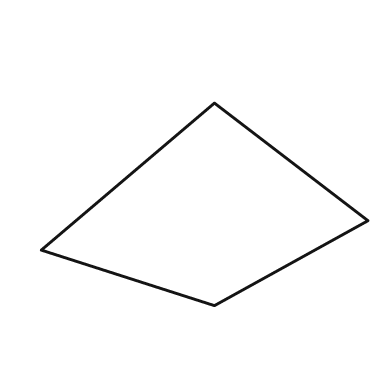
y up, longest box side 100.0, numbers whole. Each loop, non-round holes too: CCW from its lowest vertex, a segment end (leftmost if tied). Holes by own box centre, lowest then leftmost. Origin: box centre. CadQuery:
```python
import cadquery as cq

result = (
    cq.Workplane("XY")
    .moveTo(3.0, -31.0)
    .lineTo(50.0, -5.0)
    .lineTo(3.0, 31.0)
    .lineTo(-50.0, -14.0)
    .close()
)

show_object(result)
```